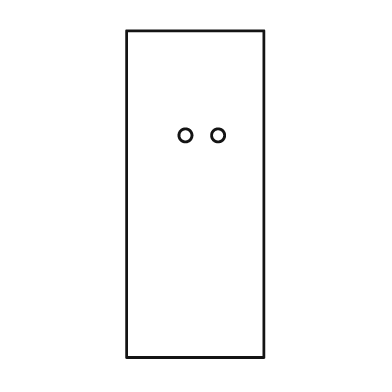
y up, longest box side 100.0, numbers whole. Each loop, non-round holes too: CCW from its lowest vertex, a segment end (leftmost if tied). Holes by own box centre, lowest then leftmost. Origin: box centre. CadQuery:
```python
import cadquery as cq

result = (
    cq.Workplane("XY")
    .moveTo(-21.0, -50.0)
    .lineTo(21.0, -50.0)
    .lineTo(21.0, 50.0)
    .lineTo(-21.0, 50.0)
    .close()
    .moveTo(-3.0, 18.0)
    .circle(2.0)
    .moveTo(7.0, 18.0)
    .circle(2.0)
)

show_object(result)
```